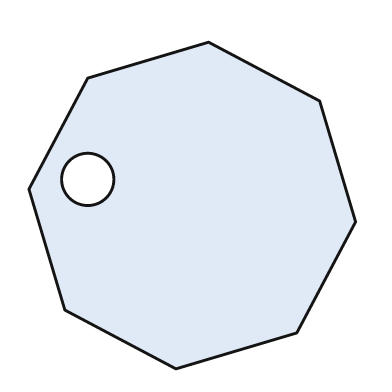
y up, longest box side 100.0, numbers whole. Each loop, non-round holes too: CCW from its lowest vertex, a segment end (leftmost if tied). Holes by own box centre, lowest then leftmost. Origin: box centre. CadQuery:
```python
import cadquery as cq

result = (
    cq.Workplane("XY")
    .moveTo(-5.0, -50.0)
    .lineTo(32.0, -39.0)
    .lineTo(50.0, -5.0)
    .lineTo(39.0, 32.0)
    .lineTo(5.0, 50.0)
    .lineTo(-32.0, 39.0)
    .lineTo(-50.0, 5.0)
    .lineTo(-39.0, -32.0)
    .close()
    .moveTo(-32.0, 8.0)
    .circle(8.0)
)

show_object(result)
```